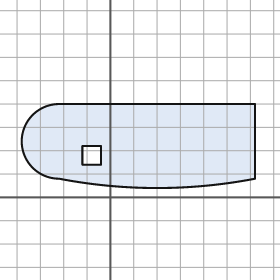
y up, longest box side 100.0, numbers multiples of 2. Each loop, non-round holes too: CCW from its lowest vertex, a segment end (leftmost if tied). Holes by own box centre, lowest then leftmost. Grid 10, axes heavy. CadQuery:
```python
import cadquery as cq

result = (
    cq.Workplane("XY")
    .moveTo(-22.0, 8.0)
    .threePointArc((20.0, 4.0), (62.0, 8.0))
    .lineTo(62.0, 40.0)
    .lineTo(-22.0, 40.0)
    .threePointArc((-38.0, 24.0), (-22.0, 8.0))
    .close()
    .moveTo(-12.0, 14.0)
    .lineTo(-4.0, 14.0)
    .lineTo(-4.0, 22.0)
    .lineTo(-12.0, 22.0)
    .close()
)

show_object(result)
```